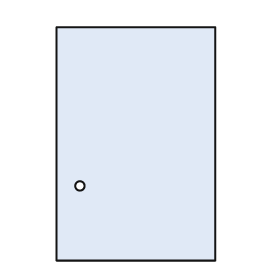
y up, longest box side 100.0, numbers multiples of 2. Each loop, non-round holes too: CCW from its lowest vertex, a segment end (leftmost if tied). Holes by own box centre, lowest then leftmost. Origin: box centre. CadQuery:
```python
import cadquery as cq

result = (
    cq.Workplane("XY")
    .moveTo(-34.0, -50.0)
    .lineTo(34.0, -50.0)
    .lineTo(34.0, 50.0)
    .lineTo(-34.0, 50.0)
    .close()
    .moveTo(-24.0, -18.0)
    .circle(2.0)
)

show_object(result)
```